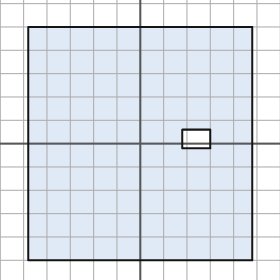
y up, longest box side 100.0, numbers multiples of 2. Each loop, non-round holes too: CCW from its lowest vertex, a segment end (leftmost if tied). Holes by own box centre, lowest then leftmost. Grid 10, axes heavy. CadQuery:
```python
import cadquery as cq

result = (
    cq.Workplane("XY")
    .moveTo(-48.0, -50.0)
    .lineTo(48.0, -50.0)
    .lineTo(48.0, 50.0)
    .lineTo(-48.0, 50.0)
    .close()
    .moveTo(18.0, -2.0)
    .lineTo(30.0, -2.0)
    .lineTo(30.0, 6.0)
    .lineTo(18.0, 6.0)
    .close()
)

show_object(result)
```